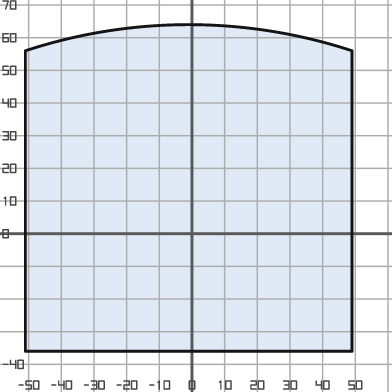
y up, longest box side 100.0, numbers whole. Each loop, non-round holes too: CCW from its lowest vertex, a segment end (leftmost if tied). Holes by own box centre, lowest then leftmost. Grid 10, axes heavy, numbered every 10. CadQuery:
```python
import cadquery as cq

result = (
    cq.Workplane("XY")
    .moveTo(-51.0, -36.0)
    .lineTo(49.0, -36.0)
    .lineTo(49.0, 56.0)
    .threePointArc((-1.0, 64.0), (-51.0, 56.0))
    .close()
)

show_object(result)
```